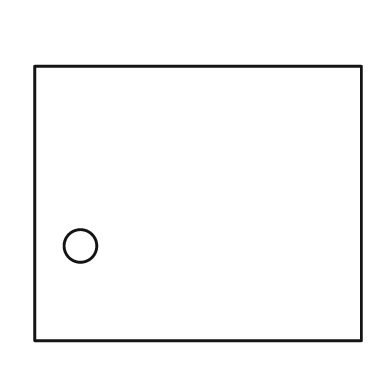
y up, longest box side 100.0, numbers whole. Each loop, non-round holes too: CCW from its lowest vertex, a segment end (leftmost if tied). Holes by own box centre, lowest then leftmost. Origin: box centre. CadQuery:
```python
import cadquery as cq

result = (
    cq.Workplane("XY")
    .moveTo(-50.0, -42.0)
    .lineTo(50.0, -42.0)
    .lineTo(50.0, 42.0)
    .lineTo(-50.0, 42.0)
    .close()
    .moveTo(-36.0, -13.0)
    .circle(5.0)
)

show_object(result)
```